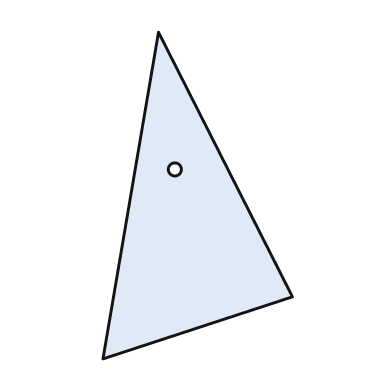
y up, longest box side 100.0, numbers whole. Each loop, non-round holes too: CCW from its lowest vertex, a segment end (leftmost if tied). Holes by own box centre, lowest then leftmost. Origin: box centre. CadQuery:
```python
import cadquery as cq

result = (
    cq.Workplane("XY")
    .moveTo(-29.0, -50.0)
    .lineTo(29.0, -31.0)
    .lineTo(-12.0, 50.0)
    .close()
    .moveTo(-7.0, 8.0)
    .circle(2.0)
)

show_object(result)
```